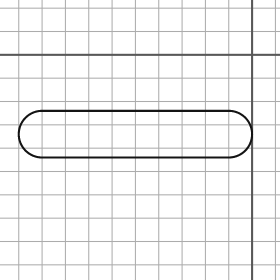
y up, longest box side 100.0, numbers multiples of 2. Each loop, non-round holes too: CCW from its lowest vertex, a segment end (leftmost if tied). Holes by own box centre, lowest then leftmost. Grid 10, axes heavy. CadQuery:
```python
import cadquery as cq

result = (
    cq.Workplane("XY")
    .moveTo(-90.0, -44.0)
    .lineTo(-10.0, -44.0)
    .threePointArc((0.0, -34.0), (-10.0, -24.0))
    .lineTo(-90.0, -24.0)
    .threePointArc((-100.0, -34.0), (-90.0, -44.0))
    .close()
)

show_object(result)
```